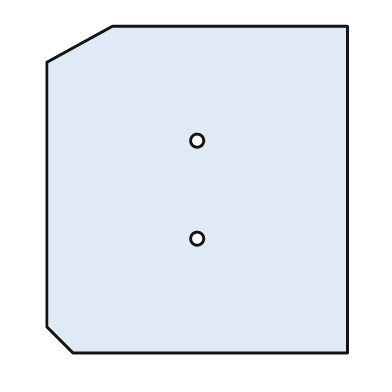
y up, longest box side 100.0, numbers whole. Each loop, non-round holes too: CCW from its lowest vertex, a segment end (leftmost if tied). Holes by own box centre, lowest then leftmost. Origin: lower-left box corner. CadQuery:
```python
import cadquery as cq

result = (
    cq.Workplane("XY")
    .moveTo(8.0, 0.0)
    .lineTo(92.0, 0.0)
    .lineTo(92.0, 100.0)
    .lineTo(20.0, 100.0)
    .lineTo(0.0, 89.0)
    .lineTo(0.0, 8.0)
    .close()
    .moveTo(46.0, 35.0)
    .circle(2.0)
    .moveTo(46.0, 65.0)
    .circle(2.0)
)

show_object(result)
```